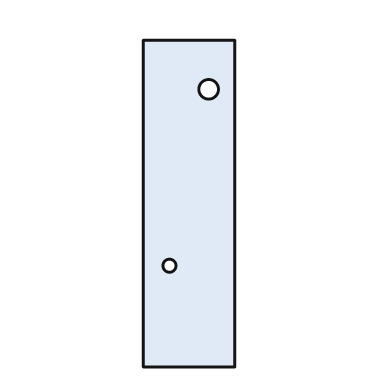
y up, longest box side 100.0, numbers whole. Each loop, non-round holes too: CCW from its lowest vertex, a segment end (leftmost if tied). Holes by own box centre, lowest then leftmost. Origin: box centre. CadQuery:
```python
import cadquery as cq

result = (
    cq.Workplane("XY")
    .moveTo(-14.0, -50.0)
    .lineTo(14.0, -50.0)
    .lineTo(14.0, 50.0)
    .lineTo(-14.0, 50.0)
    .close()
    .moveTo(-6.0, -19.0)
    .circle(2.0)
    .moveTo(6.0, 35.0)
    .circle(3.0)
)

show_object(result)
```